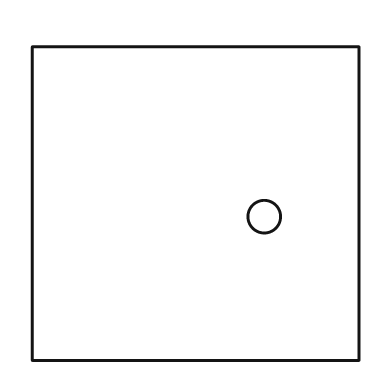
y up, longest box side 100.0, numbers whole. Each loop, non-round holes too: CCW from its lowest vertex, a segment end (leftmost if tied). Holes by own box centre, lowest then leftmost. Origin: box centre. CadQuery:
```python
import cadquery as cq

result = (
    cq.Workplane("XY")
    .moveTo(-50.0, -48.0)
    .lineTo(50.0, -48.0)
    .lineTo(50.0, 48.0)
    .lineTo(-50.0, 48.0)
    .close()
    .moveTo(21.0, -4.0)
    .circle(5.0)
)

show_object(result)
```